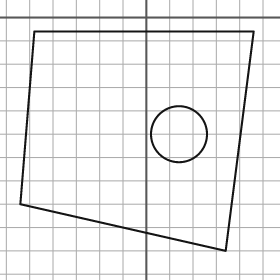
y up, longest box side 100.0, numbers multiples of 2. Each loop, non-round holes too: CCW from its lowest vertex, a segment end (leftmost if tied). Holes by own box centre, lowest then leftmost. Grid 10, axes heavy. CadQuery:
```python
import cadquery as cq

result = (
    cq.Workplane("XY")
    .moveTo(34.0, -100.0)
    .lineTo(46.0, -6.0)
    .lineTo(-48.0, -6.0)
    .lineTo(-54.0, -80.0)
    .close()
    .moveTo(14.0, -50.0)
    .circle(12.0)
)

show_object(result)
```